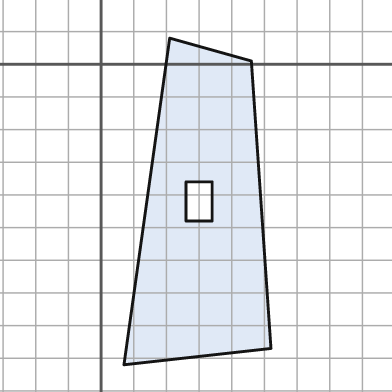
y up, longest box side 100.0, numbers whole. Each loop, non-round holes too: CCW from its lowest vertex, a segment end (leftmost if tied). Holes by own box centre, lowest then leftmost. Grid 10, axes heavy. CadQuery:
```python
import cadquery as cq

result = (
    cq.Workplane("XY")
    .moveTo(7.0, -92.0)
    .lineTo(52.0, -87.0)
    .lineTo(46.0, 1.0)
    .lineTo(21.0, 8.0)
    .close()
    .moveTo(26.0, -48.0)
    .lineTo(34.0, -48.0)
    .lineTo(34.0, -36.0)
    .lineTo(26.0, -36.0)
    .close()
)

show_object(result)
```